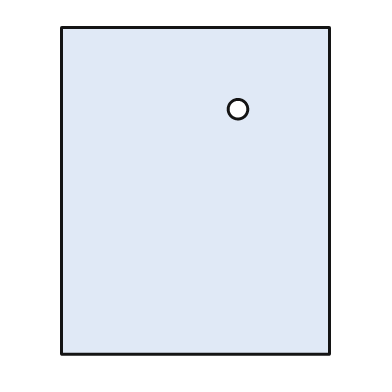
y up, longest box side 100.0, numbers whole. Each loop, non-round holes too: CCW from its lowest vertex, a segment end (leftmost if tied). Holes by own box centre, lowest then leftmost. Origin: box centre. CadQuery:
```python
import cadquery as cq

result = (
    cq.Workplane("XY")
    .moveTo(-41.0, -50.0)
    .lineTo(41.0, -50.0)
    .lineTo(41.0, 50.0)
    .lineTo(-41.0, 50.0)
    .close()
    .moveTo(13.0, 25.0)
    .circle(3.0)
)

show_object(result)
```